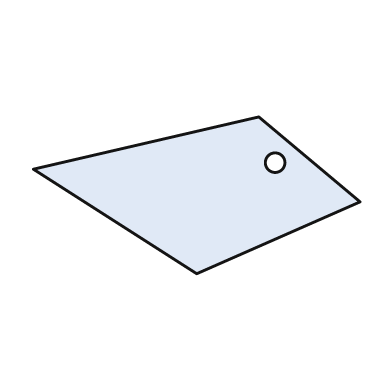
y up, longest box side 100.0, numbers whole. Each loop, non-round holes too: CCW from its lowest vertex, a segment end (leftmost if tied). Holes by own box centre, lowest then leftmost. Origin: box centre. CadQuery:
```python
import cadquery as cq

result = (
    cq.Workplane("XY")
    .moveTo(0.0, -24.0)
    .lineTo(50.0, -2.0)
    .lineTo(19.0, 24.0)
    .lineTo(-50.0, 8.0)
    .close()
    .moveTo(24.0, 10.0)
    .circle(3.0)
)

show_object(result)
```